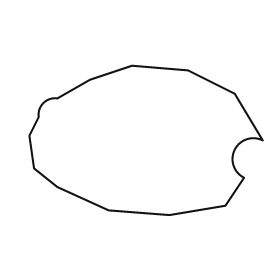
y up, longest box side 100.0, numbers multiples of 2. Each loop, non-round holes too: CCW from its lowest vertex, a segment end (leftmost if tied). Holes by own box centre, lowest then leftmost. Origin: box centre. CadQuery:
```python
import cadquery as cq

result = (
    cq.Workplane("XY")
    .moveTo(10.0, -32.0)
    .lineTo(34.0, -28.0)
    .lineTo(42.0, -16.0)
    .threePointArc((38.0, -4.0), (50.0, 0.0))
    .lineTo(38.0, 20.0)
    .lineTo(18.0, 30.0)
    .lineTo(-6.0, 32.0)
    .lineTo(-24.0, 26.0)
    .lineTo(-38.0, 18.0)
    .threePointArc((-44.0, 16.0), (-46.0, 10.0))
    .lineTo(-50.0, 2.0)
    .lineTo(-48.0, -12.0)
    .lineTo(-38.0, -20.0)
    .lineTo(-16.0, -30.0)
    .close()
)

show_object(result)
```